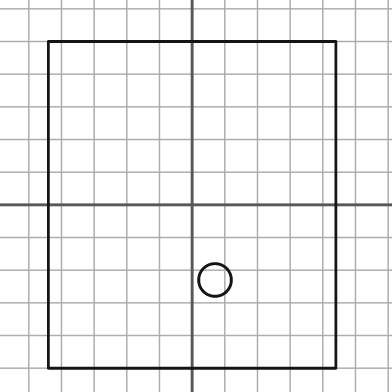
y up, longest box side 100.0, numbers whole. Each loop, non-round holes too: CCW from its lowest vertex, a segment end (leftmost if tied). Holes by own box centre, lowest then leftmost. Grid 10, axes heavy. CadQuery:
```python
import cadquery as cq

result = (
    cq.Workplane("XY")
    .moveTo(-44.0, -50.0)
    .lineTo(44.0, -50.0)
    .lineTo(44.0, 50.0)
    .lineTo(-44.0, 50.0)
    .close()
    .moveTo(7.0, -23.0)
    .circle(5.0)
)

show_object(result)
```